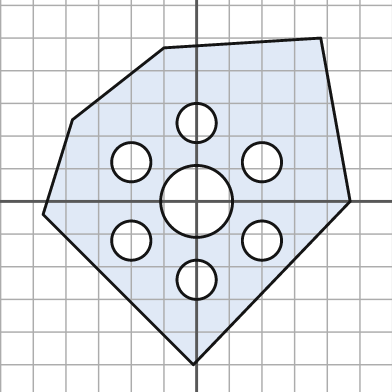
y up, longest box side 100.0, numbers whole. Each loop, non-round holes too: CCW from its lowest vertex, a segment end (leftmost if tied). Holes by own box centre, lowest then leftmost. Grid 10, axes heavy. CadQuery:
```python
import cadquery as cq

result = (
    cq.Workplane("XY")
    .moveTo(-1.0, -50.0)
    .lineTo(47.0, 0.0)
    .lineTo(38.0, 50.0)
    .lineTo(-10.0, 47.0)
    .lineTo(-38.0, 25.0)
    .lineTo(-47.0, -4.0)
    .close()
    .moveTo(0.0, -24.0)
    .circle(6.0)
    .moveTo(-20.0, -12.0)
    .circle(6.0)
    .moveTo(20.0, -12.0)
    .circle(6.0)
    .moveTo(0.0, 0.0)
    .circle(11.0)
    .moveTo(-20.0, 12.0)
    .circle(6.0)
    .moveTo(20.0, 12.0)
    .circle(6.0)
    .moveTo(0.0, 24.0)
    .circle(6.0)
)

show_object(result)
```